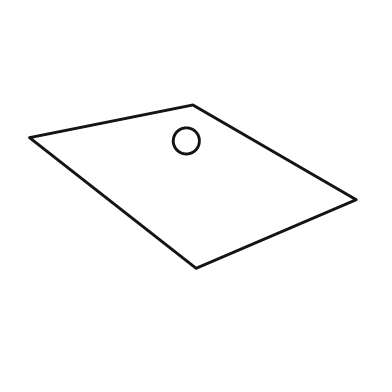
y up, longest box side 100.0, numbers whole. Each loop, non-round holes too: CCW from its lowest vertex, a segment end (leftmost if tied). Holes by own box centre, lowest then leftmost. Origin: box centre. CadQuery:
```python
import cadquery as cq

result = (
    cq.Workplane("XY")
    .moveTo(1.0, -25.0)
    .lineTo(50.0, -4.0)
    .lineTo(0.0, 25.0)
    .lineTo(-50.0, 15.0)
    .close()
    .moveTo(-2.0, 14.0)
    .circle(4.0)
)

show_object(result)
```